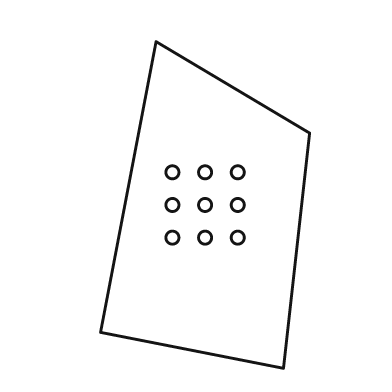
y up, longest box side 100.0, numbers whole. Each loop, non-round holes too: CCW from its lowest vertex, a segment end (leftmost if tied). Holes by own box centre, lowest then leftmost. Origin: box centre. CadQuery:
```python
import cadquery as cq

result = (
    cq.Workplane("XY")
    .moveTo(24.0, -50.0)
    .lineTo(32.0, 22.0)
    .lineTo(-15.0, 50.0)
    .lineTo(-32.0, -39.0)
    .close()
    .moveTo(-10.0, -10.0)
    .circle(2.0)
    .moveTo(0.0, -10.0)
    .circle(2.0)
    .moveTo(10.0, -10.0)
    .circle(2.0)
    .moveTo(-10.0, 0.0)
    .circle(2.0)
    .moveTo(0.0, 0.0)
    .circle(2.0)
    .moveTo(10.0, 0.0)
    .circle(2.0)
    .moveTo(-10.0, 10.0)
    .circle(2.0)
    .moveTo(0.0, 10.0)
    .circle(2.0)
    .moveTo(10.0, 10.0)
    .circle(2.0)
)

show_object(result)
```